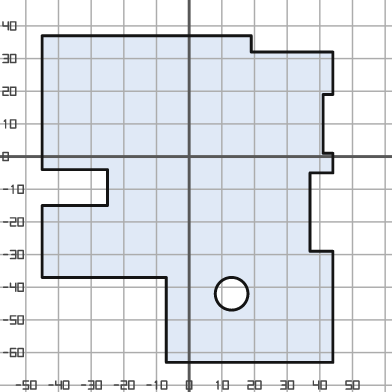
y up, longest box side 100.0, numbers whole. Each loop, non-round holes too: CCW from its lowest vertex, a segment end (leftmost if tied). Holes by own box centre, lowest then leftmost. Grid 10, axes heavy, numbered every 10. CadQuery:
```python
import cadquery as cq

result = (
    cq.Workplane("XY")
    .moveTo(-7.0, -63.0)
    .lineTo(44.0, -63.0)
    .lineTo(44.0, -29.0)
    .lineTo(37.0, -29.0)
    .lineTo(37.0, -5.0)
    .lineTo(44.0, -5.0)
    .lineTo(44.0, 1.0)
    .lineTo(41.0, 1.0)
    .lineTo(41.0, 19.0)
    .lineTo(44.0, 19.0)
    .lineTo(44.0, 32.0)
    .lineTo(19.0, 32.0)
    .lineTo(19.0, 37.0)
    .lineTo(-45.0, 37.0)
    .lineTo(-45.0, -4.0)
    .lineTo(-25.0, -4.0)
    .lineTo(-25.0, -15.0)
    .lineTo(-45.0, -15.0)
    .lineTo(-45.0, -37.0)
    .lineTo(-7.0, -37.0)
    .close()
    .moveTo(13.0, -42.0)
    .circle(5.0)
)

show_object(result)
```